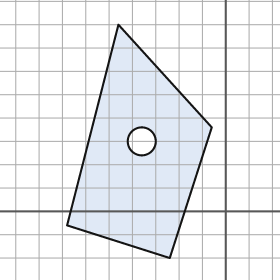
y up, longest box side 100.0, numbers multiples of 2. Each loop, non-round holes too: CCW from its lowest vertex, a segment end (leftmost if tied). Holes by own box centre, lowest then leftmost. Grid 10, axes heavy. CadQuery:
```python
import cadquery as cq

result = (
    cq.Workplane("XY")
    .moveTo(-24.0, -20.0)
    .lineTo(-6.0, 36.0)
    .lineTo(-46.0, 80.0)
    .lineTo(-68.0, -6.0)
    .close()
    .moveTo(-36.0, 30.0)
    .circle(6.0)
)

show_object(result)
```